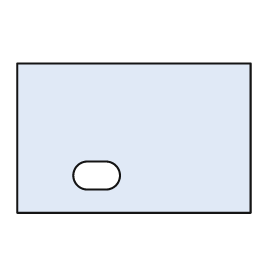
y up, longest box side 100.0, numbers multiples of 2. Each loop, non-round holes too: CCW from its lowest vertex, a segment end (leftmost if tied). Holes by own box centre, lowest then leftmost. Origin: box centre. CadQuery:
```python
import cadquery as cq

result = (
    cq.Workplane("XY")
    .moveTo(-50.0, -32.0)
    .lineTo(50.0, -32.0)
    .lineTo(50.0, 32.0)
    .lineTo(-50.0, 32.0)
    .close()
    .moveTo(-20.0, -22.0)
    .lineTo(-12.0, -22.0)
    .threePointArc((-6.0, -16.0), (-12.0, -10.0))
    .lineTo(-20.0, -10.0)
    .threePointArc((-26.0, -16.0), (-20.0, -22.0))
    .close()
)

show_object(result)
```